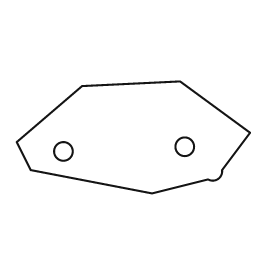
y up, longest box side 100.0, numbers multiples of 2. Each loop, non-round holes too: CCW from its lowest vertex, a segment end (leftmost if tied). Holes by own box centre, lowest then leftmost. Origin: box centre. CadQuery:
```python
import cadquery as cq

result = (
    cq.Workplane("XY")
    .moveTo(8.0, -24.0)
    .lineTo(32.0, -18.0)
    .threePointArc((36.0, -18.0), (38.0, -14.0))
    .lineTo(50.0, 2.0)
    .lineTo(20.0, 24.0)
    .lineTo(-22.0, 22.0)
    .lineTo(-50.0, -2.0)
    .lineTo(-44.0, -14.0)
    .close()
    .moveTo(-30.0, -6.0)
    .circle(4.0)
    .moveTo(22.0, -4.0)
    .circle(4.0)
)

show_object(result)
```